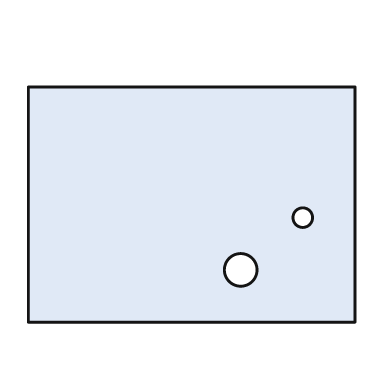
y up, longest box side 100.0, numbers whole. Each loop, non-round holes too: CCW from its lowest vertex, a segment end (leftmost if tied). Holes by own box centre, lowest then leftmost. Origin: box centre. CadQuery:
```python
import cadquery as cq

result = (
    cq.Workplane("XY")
    .moveTo(-50.0, -36.0)
    .lineTo(50.0, -36.0)
    .lineTo(50.0, 36.0)
    .lineTo(-50.0, 36.0)
    .close()
    .moveTo(15.0, -20.0)
    .circle(5.0)
    .moveTo(34.0, -4.0)
    .circle(3.0)
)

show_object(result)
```